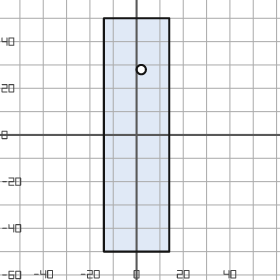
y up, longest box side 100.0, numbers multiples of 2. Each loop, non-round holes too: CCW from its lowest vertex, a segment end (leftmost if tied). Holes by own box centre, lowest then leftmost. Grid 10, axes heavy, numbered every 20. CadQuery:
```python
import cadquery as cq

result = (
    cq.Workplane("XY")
    .moveTo(-14.0, -50.0)
    .lineTo(14.0, -50.0)
    .lineTo(14.0, 50.0)
    .lineTo(-14.0, 50.0)
    .close()
    .moveTo(2.0, 28.0)
    .circle(2.0)
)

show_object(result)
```